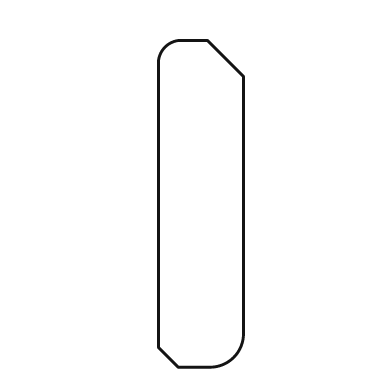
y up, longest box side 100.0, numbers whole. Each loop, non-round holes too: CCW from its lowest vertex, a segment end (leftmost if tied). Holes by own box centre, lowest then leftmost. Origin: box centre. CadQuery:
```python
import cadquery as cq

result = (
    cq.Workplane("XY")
    .moveTo(-7.0, -50.0)
    .lineTo(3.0, -50.0)
    .threePointArc((10.0, -47.0), (13.0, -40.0))
    .lineTo(13.0, 39.0)
    .lineTo(2.0, 50.0)
    .lineTo(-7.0, 50.0)
    .threePointArc((-11.0, 48.0), (-13.0, 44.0))
    .lineTo(-13.0, -44.0)
    .close()
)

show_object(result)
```